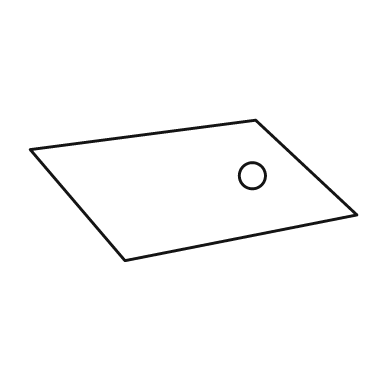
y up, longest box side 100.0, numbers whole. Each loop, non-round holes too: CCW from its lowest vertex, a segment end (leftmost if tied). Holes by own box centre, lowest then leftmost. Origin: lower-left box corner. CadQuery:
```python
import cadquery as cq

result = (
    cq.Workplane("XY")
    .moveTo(29.0, 0.0)
    .lineTo(100.0, 14.0)
    .lineTo(69.0, 43.0)
    .lineTo(0.0, 34.0)
    .close()
    .moveTo(68.0, 26.0)
    .circle(4.0)
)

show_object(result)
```